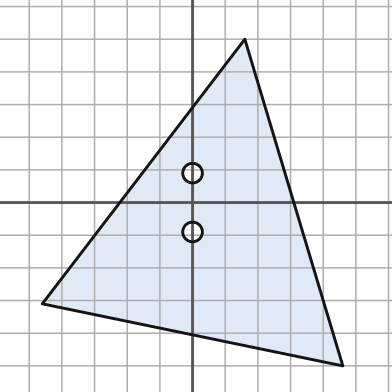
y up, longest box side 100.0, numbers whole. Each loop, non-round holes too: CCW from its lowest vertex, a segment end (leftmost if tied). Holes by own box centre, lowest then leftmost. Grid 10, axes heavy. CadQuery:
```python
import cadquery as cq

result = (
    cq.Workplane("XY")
    .moveTo(46.0, -50.0)
    .lineTo(16.0, 50.0)
    .lineTo(-46.0, -31.0)
    .close()
    .moveTo(0.0, -9.0)
    .circle(3.0)
    .moveTo(0.0, 9.0)
    .circle(3.0)
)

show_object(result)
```